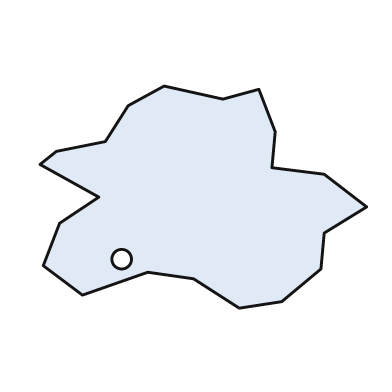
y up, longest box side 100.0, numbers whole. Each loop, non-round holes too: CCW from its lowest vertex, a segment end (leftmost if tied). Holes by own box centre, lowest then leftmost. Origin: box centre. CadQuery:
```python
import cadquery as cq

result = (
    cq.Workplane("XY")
    .moveTo(11.0, -34.0)
    .lineTo(24.0, -32.0)
    .lineTo(36.0, -22.0)
    .lineTo(37.0, -11.0)
    .lineTo(50.0, -3.0)
    .lineTo(37.0, 7.0)
    .lineTo(21.0, 9.0)
    .lineTo(22.0, 20.0)
    .lineTo(17.0, 33.0)
    .lineTo(6.0, 30.0)
    .lineTo(-12.0, 34.0)
    .lineTo(-23.0, 28.0)
    .lineTo(-30.0, 17.0)
    .lineTo(-45.0, 14.0)
    .lineTo(-50.0, 10.0)
    .lineTo(-32.0, 0.0)
    .lineTo(-44.0, -8.0)
    .lineTo(-49.0, -21.0)
    .lineTo(-37.0, -30.0)
    .lineTo(-17.0, -23.0)
    .lineTo(-3.0, -25.0)
    .close()
    .moveTo(-25.0, -19.0)
    .circle(3.0)
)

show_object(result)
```